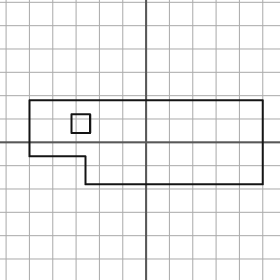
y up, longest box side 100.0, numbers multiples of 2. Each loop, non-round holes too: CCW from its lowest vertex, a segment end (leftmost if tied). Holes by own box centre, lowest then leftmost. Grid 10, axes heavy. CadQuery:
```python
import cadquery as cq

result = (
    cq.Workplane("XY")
    .moveTo(-26.0, -18.0)
    .lineTo(50.0, -18.0)
    .lineTo(50.0, 18.0)
    .lineTo(-50.0, 18.0)
    .lineTo(-50.0, -6.0)
    .lineTo(-26.0, -6.0)
    .close()
    .moveTo(-32.0, 4.0)
    .lineTo(-24.0, 4.0)
    .lineTo(-24.0, 12.0)
    .lineTo(-32.0, 12.0)
    .close()
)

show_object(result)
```